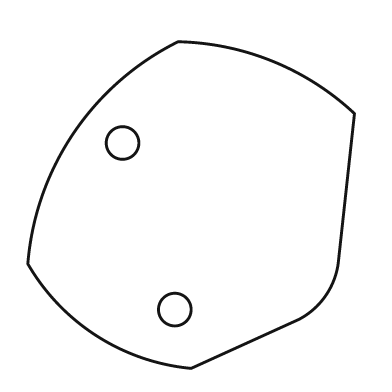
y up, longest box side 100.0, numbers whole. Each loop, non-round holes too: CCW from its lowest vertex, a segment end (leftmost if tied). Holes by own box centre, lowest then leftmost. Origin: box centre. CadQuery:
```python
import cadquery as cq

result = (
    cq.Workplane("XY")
    .moveTo(0.0, -50.0)
    .lineTo(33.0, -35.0)
    .threePointArc((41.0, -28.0), (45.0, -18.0))
    .lineTo(50.0, 28.0)
    .threePointArc((25.0, 44.0), (-4.0, 50.0))
    .threePointArc((-36.0, 22.0), (-50.0, -18.0))
    .threePointArc((-29.0, -40.0), (0.0, -50.0))
    .close()
    .moveTo(-5.0, -32.0)
    .circle(5.0)
    .moveTo(-21.0, 19.0)
    .circle(5.0)
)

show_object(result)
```